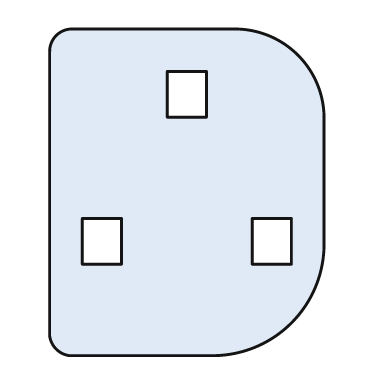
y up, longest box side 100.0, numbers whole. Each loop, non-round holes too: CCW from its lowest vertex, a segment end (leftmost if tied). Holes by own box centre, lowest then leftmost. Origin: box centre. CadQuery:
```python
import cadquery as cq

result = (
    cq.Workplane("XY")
    .moveTo(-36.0, -50.0)
    .lineTo(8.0, -50.0)
    .threePointArc((32.0, -40.0), (42.0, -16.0))
    .lineTo(42.0, 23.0)
    .threePointArc((34.0, 42.0), (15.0, 50.0))
    .lineTo(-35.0, 50.0)
    .threePointArc((-40.0, 48.0), (-42.0, 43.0))
    .lineTo(-42.0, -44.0)
    .threePointArc((-40.0, -48.0), (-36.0, -50.0))
    .close()
    .moveTo(-32.0, -22.0)
    .lineTo(-20.0, -22.0)
    .lineTo(-20.0, -8.0)
    .lineTo(-32.0, -8.0)
    .close()
    .moveTo(20.0, -22.0)
    .lineTo(32.0, -22.0)
    .lineTo(32.0, -8.0)
    .lineTo(20.0, -8.0)
    .close()
    .moveTo(-6.0, 23.0)
    .lineTo(6.0, 23.0)
    .lineTo(6.0, 37.0)
    .lineTo(-6.0, 37.0)
    .close()
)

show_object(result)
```